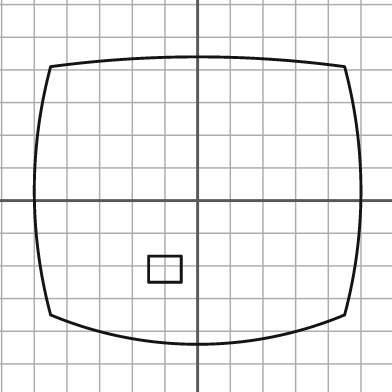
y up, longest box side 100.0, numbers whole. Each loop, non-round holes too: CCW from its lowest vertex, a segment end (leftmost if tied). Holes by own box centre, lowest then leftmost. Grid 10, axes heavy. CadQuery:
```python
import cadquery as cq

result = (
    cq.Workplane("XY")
    .moveTo(-45.0, -35.0)
    .threePointArc((0.0, -44.0), (45.0, -35.0))
    .threePointArc((50.0, 3.0), (45.0, 41.0))
    .threePointArc((0.0, 44.0), (-45.0, 41.0))
    .threePointArc((-50.0, 3.0), (-45.0, -35.0))
    .close()
    .moveTo(-15.0, -25.0)
    .lineTo(-5.0, -25.0)
    .lineTo(-5.0, -17.0)
    .lineTo(-15.0, -17.0)
    .close()
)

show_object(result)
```